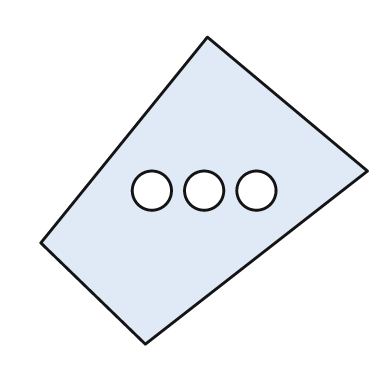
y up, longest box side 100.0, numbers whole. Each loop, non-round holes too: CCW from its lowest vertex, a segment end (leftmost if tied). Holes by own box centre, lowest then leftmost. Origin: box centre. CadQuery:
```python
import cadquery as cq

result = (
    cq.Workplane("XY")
    .moveTo(-18.0, -47.0)
    .lineTo(50.0, 6.0)
    .lineTo(1.0, 47.0)
    .lineTo(-50.0, -16.0)
    .close()
    .moveTo(-16.0, 0.0)
    .circle(6.0)
    .moveTo(0.0, 0.0)
    .circle(6.0)
    .moveTo(16.0, 0.0)
    .circle(6.0)
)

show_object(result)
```